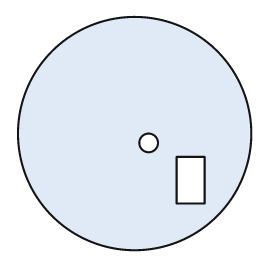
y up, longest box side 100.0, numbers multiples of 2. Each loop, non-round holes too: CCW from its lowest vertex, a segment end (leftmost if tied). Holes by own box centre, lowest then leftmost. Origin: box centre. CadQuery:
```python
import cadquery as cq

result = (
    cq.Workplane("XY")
    .moveTo(0.0, 0.0)
    .circle(50.0)
    .moveTo(18.0, -30.0)
    .lineTo(30.0, -30.0)
    .lineTo(30.0, -10.0)
    .lineTo(18.0, -10.0)
    .close()
    .moveTo(6.0, -4.0)
    .circle(4.0)
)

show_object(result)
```